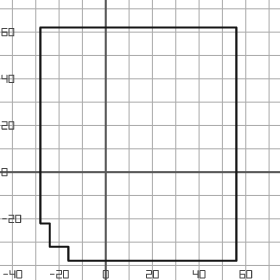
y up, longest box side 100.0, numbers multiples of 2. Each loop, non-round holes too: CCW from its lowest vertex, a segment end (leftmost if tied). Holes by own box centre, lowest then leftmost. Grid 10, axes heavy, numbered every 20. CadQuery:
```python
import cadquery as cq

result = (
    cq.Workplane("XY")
    .moveTo(-16.0, -38.0)
    .lineTo(56.0, -38.0)
    .lineTo(56.0, 62.0)
    .lineTo(-28.0, 62.0)
    .lineTo(-28.0, -22.0)
    .lineTo(-24.0, -22.0)
    .lineTo(-24.0, -32.0)
    .lineTo(-16.0, -32.0)
    .close()
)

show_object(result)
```